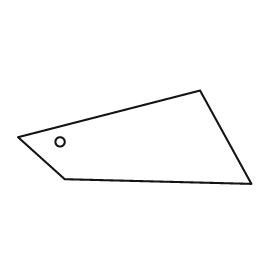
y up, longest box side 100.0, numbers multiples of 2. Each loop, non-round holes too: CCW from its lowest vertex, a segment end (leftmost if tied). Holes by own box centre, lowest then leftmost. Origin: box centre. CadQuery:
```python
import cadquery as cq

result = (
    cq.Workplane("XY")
    .moveTo(50.0, -20.0)
    .lineTo(28.0, 20.0)
    .lineTo(-50.0, 0.0)
    .lineTo(-30.0, -18.0)
    .close()
    .moveTo(-32.0, -2.0)
    .circle(2.0)
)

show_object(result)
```